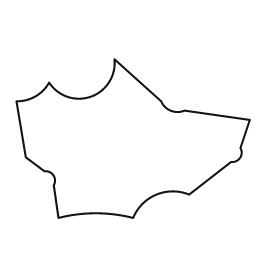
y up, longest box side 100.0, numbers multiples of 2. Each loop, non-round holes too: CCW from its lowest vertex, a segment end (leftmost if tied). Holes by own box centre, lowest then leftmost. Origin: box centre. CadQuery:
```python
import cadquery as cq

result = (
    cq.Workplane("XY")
    .moveTo(-32.0, -34.0)
    .threePointArc((-16.0, -32.0), (0.0, -34.0))
    .threePointArc((10.0, -24.0), (24.0, -24.0))
    .lineTo(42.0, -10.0)
    .threePointArc((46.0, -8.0), (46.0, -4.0))
    .lineTo(50.0, 8.0)
    .lineTo(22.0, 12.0)
    .threePointArc((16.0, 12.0), (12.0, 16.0))
    .lineTo(-8.0, 34.0)
    .threePointArc((-18.0, 18.0), (-36.0, 24.0))
    .threePointArc((-42.0, 18.0), (-50.0, 16.0))
    .lineTo(-46.0, -8.0)
    .lineTo(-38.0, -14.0)
    .threePointArc((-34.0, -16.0), (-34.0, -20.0))
    .close()
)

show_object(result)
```